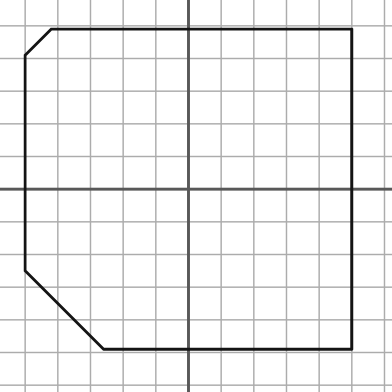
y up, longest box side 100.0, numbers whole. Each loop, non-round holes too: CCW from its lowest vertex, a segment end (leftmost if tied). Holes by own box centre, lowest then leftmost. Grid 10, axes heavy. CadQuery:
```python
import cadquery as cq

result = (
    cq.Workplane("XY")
    .moveTo(-26.0, -49.0)
    .lineTo(50.0, -49.0)
    .lineTo(50.0, 49.0)
    .lineTo(-42.0, 49.0)
    .lineTo(-50.0, 41.0)
    .lineTo(-50.0, -25.0)
    .close()
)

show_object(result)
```